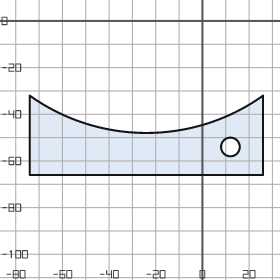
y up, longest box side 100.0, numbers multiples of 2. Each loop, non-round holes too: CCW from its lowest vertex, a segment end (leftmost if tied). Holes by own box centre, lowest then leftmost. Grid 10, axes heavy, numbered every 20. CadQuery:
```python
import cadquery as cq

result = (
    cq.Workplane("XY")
    .moveTo(-74.0, -66.0)
    .lineTo(26.0, -66.0)
    .lineTo(26.0, -32.0)
    .threePointArc((-24.0, -48.0), (-74.0, -32.0))
    .close()
    .moveTo(12.0, -54.0)
    .circle(4.0)
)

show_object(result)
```